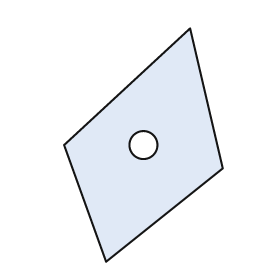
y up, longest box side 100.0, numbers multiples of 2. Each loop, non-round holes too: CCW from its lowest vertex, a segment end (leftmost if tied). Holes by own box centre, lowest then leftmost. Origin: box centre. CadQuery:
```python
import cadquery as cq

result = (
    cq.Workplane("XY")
    .moveTo(-16.0, -50.0)
    .lineTo(34.0, -10.0)
    .lineTo(20.0, 50.0)
    .lineTo(-34.0, 0.0)
    .close()
    .moveTo(0.0, 0.0)
    .circle(6.0)
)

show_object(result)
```